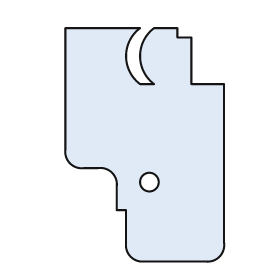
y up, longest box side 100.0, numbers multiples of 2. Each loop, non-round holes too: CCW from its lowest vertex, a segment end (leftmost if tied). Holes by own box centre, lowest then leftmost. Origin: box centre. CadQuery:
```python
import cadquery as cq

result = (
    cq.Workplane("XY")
    .moveTo(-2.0, -50.0)
    .lineTo(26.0, -50.0)
    .threePointArc((32.0, -48.0), (34.0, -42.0))
    .lineTo(34.0, 26.0)
    .lineTo(20.0, 26.0)
    .lineTo(20.0, 46.0)
    .lineTo(14.0, 46.0)
    .lineTo(14.0, 50.0)
    .lineTo(4.0, 50.0)
    .threePointArc((-2.0, 38.0), (4.0, 26.0))
    .lineTo(-2.0, 26.0)
    .threePointArc((-8.0, 38.0), (-2.0, 50.0))
    .lineTo(-34.0, 50.0)
    .lineTo(-34.0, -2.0)
    .threePointArc((-32.0, -8.0), (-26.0, -10.0))
    .lineTo(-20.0, -10.0)
    .threePointArc((-14.0, -12.0), (-12.0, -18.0))
    .lineTo(-12.0, -28.0)
    .lineTo(-8.0, -28.0)
    .lineTo(-8.0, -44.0)
    .threePointArc((-6.0, -48.0), (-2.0, -50.0))
    .close()
    .moveTo(2.0, -16.0)
    .circle(4.0)
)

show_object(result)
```